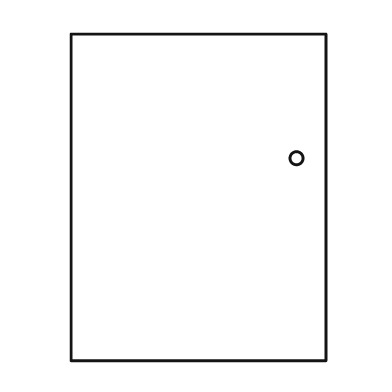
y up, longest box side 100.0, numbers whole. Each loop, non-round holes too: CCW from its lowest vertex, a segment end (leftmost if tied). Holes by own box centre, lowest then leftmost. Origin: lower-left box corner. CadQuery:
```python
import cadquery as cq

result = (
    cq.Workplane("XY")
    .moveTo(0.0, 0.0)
    .lineTo(78.0, 0.0)
    .lineTo(78.0, 100.0)
    .lineTo(0.0, 100.0)
    .close()
    .moveTo(69.0, 62.0)
    .circle(2.0)
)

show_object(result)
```